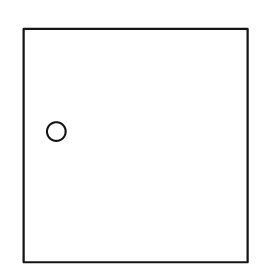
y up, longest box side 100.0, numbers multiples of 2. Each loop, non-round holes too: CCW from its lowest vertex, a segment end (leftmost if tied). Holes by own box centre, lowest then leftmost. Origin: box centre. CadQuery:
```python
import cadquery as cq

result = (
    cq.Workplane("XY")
    .moveTo(-48.0, -50.0)
    .lineTo(48.0, -50.0)
    .lineTo(48.0, 50.0)
    .lineTo(-48.0, 50.0)
    .close()
    .moveTo(-34.0, 6.0)
    .circle(4.0)
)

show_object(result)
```